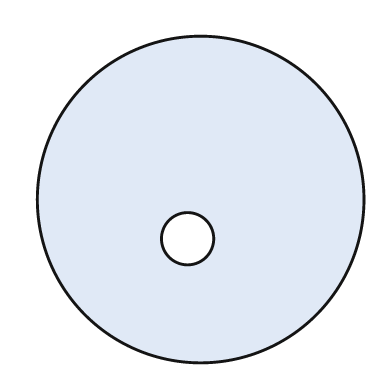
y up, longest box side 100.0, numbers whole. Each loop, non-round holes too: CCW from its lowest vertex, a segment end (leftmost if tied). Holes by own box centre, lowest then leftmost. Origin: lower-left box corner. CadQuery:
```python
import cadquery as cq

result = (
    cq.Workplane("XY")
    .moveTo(50.0, 50.0)
    .circle(50.0)
    .moveTo(46.0, 38.0)
    .circle(8.0)
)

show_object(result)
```